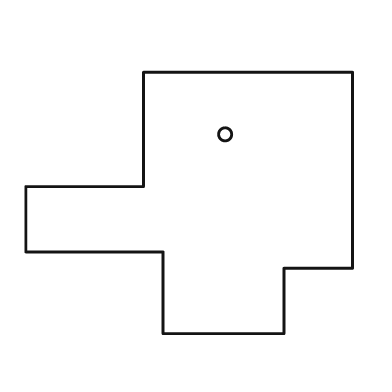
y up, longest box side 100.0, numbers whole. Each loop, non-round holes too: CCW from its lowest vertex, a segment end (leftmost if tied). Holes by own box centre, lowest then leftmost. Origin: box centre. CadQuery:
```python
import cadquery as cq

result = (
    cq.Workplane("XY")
    .moveTo(-8.0, -40.0)
    .lineTo(29.0, -40.0)
    .lineTo(29.0, -20.0)
    .lineTo(50.0, -20.0)
    .lineTo(50.0, 40.0)
    .lineTo(-14.0, 40.0)
    .lineTo(-14.0, 5.0)
    .lineTo(-50.0, 5.0)
    .lineTo(-50.0, -15.0)
    .lineTo(-8.0, -15.0)
    .close()
    .moveTo(11.0, 21.0)
    .circle(2.0)
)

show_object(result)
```